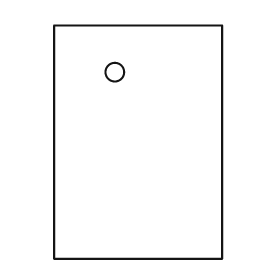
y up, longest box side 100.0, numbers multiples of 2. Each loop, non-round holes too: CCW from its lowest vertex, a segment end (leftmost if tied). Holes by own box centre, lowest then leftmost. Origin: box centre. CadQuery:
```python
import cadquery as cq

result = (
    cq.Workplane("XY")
    .moveTo(-36.0, -50.0)
    .lineTo(36.0, -50.0)
    .lineTo(36.0, 50.0)
    .lineTo(-36.0, 50.0)
    .close()
    .moveTo(-10.0, 30.0)
    .circle(4.0)
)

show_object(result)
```